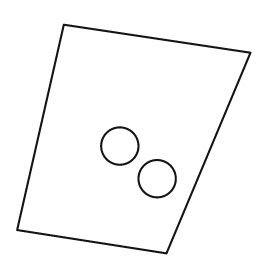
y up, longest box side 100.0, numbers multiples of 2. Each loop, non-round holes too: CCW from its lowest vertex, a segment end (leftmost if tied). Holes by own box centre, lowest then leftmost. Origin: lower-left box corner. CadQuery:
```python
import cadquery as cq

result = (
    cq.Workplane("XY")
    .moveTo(64.0, 0.0)
    .lineTo(100.0, 86.0)
    .lineTo(20.0, 98.0)
    .lineTo(0.0, 10.0)
    .close()
    .moveTo(60.0, 32.0)
    .circle(8.0)
    .moveTo(44.0, 46.0)
    .circle(8.0)
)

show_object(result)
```